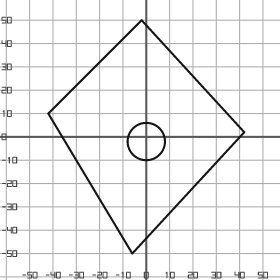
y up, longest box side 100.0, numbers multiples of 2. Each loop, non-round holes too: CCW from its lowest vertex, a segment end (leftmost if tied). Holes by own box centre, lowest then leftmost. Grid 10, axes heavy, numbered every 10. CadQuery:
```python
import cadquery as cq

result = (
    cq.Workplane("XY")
    .moveTo(-6.0, -50.0)
    .lineTo(42.0, 2.0)
    .lineTo(-2.0, 50.0)
    .lineTo(-42.0, 10.0)
    .close()
    .moveTo(0.0, -2.0)
    .circle(8.0)
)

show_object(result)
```